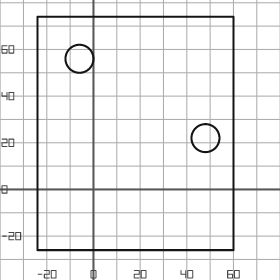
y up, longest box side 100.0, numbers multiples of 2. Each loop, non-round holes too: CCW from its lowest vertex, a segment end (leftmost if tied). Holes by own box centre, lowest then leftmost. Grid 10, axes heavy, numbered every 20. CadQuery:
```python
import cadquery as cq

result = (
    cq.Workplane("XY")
    .moveTo(-24.0, -26.0)
    .lineTo(60.0, -26.0)
    .lineTo(60.0, 74.0)
    .lineTo(-24.0, 74.0)
    .close()
    .moveTo(48.0, 22.0)
    .circle(6.0)
    .moveTo(-6.0, 56.0)
    .circle(6.0)
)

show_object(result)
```